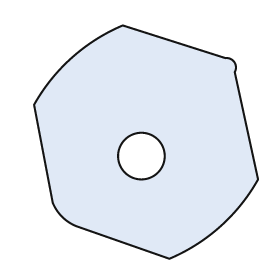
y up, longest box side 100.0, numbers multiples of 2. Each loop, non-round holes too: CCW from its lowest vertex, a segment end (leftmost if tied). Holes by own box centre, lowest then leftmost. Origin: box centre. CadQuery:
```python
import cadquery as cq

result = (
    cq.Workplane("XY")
    .moveTo(10.0, -50.0)
    .threePointArc((32.0, -36.0), (48.0, -16.0))
    .lineTo(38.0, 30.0)
    .threePointArc((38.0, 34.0), (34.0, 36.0))
    .lineTo(-10.0, 50.0)
    .threePointArc((-32.0, 36.0), (-48.0, 16.0))
    .lineTo(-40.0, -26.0)
    .threePointArc((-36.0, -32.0), (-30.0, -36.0))
    .close()
    .moveTo(-2.0, -6.0)
    .circle(10.0)
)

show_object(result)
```